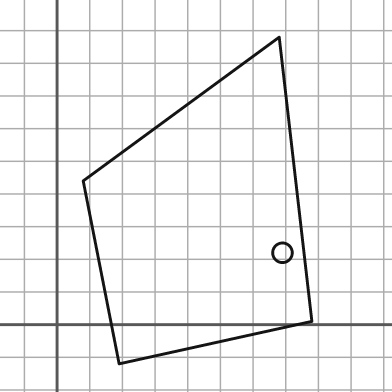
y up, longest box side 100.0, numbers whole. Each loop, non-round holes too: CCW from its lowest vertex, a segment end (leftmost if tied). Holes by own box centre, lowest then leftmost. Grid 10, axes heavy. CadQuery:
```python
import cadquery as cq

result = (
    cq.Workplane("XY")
    .moveTo(19.0, -12.0)
    .lineTo(78.0, 1.0)
    .lineTo(68.0, 88.0)
    .lineTo(8.0, 44.0)
    .close()
    .moveTo(69.0, 22.0)
    .circle(3.0)
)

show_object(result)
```